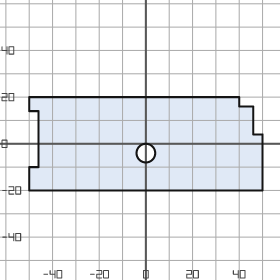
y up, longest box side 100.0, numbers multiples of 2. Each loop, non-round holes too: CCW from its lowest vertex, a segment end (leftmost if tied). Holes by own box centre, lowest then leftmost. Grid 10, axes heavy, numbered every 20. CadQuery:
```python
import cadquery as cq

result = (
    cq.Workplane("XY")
    .moveTo(-50.0, -20.0)
    .lineTo(50.0, -20.0)
    .lineTo(50.0, 4.0)
    .lineTo(46.0, 4.0)
    .lineTo(46.0, 16.0)
    .lineTo(40.0, 16.0)
    .lineTo(40.0, 20.0)
    .lineTo(-50.0, 20.0)
    .lineTo(-50.0, 14.0)
    .lineTo(-46.0, 14.0)
    .lineTo(-46.0, -10.0)
    .lineTo(-50.0, -10.0)
    .close()
    .moveTo(0.0, -4.0)
    .circle(4.0)
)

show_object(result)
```